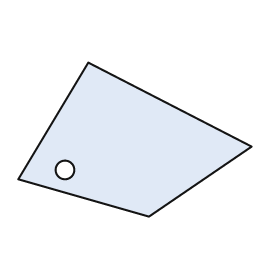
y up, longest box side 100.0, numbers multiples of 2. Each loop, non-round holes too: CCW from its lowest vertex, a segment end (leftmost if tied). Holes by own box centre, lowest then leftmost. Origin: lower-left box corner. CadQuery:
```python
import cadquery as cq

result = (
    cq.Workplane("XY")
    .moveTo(56.0, 0.0)
    .lineTo(100.0, 30.0)
    .lineTo(30.0, 66.0)
    .lineTo(0.0, 16.0)
    .close()
    .moveTo(20.0, 20.0)
    .circle(4.0)
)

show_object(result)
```